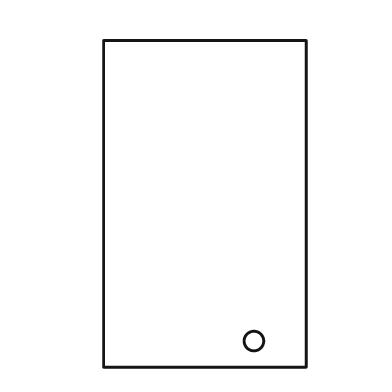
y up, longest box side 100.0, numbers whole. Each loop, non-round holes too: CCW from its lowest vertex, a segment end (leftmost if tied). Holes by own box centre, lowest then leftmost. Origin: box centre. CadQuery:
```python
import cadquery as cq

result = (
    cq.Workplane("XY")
    .moveTo(-31.0, -50.0)
    .lineTo(31.0, -50.0)
    .lineTo(31.0, 50.0)
    .lineTo(-31.0, 50.0)
    .close()
    .moveTo(15.0, -42.0)
    .circle(3.0)
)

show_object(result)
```